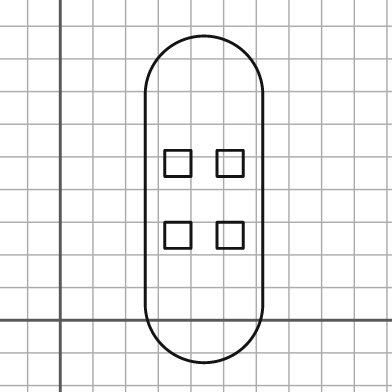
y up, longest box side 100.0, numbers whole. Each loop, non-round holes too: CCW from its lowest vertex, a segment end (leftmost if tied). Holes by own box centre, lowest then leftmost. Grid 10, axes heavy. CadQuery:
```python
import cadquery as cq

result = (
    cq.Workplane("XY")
    .moveTo(26.0, 5.0)
    .threePointArc((44.0, -13.0), (62.0, 5.0))
    .lineTo(62.0, 69.0)
    .threePointArc((44.0, 87.0), (26.0, 69.0))
    .close()
    .moveTo(32.0, 22.0)
    .lineTo(40.0, 22.0)
    .lineTo(40.0, 30.0)
    .lineTo(32.0, 30.0)
    .close()
    .moveTo(48.0, 22.0)
    .lineTo(56.0, 22.0)
    .lineTo(56.0, 30.0)
    .lineTo(48.0, 30.0)
    .close()
    .moveTo(32.0, 44.0)
    .lineTo(40.0, 44.0)
    .lineTo(40.0, 52.0)
    .lineTo(32.0, 52.0)
    .close()
    .moveTo(48.0, 44.0)
    .lineTo(56.0, 44.0)
    .lineTo(56.0, 52.0)
    .lineTo(48.0, 52.0)
    .close()
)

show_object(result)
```